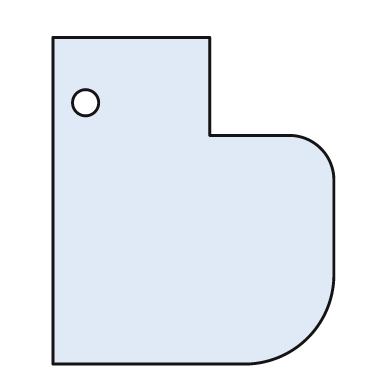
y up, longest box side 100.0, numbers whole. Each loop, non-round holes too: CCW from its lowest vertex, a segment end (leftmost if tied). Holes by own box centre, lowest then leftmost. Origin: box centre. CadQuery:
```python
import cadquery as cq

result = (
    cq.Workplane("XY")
    .moveTo(-43.0, -50.0)
    .lineTo(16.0, -50.0)
    .threePointArc((35.0, -42.0), (43.0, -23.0))
    .lineTo(43.0, 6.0)
    .threePointArc((39.0, 16.0), (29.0, 20.0))
    .lineTo(5.0, 20.0)
    .lineTo(5.0, 50.0)
    .lineTo(-43.0, 50.0)
    .close()
    .moveTo(-33.0, 30.0)
    .circle(4.0)
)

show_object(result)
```